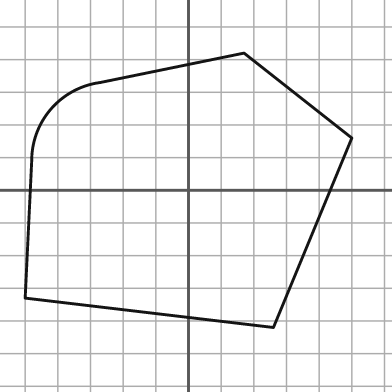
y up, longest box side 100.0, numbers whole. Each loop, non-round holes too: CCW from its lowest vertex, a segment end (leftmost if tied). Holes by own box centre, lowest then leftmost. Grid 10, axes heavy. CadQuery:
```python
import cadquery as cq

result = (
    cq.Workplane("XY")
    .moveTo(26.0, -42.0)
    .lineTo(50.0, 16.0)
    .lineTo(17.0, 42.0)
    .lineTo(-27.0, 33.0)
    .threePointArc((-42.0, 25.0), (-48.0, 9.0))
    .lineTo(-50.0, -33.0)
    .close()
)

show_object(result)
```